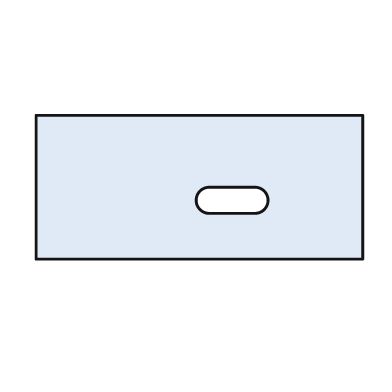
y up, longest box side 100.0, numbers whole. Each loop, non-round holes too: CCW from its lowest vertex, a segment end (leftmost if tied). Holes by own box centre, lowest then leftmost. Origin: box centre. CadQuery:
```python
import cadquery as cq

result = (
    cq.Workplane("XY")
    .moveTo(-50.0, -22.0)
    .lineTo(50.0, -22.0)
    .lineTo(50.0, 22.0)
    .lineTo(-50.0, 22.0)
    .close()
    .moveTo(3.0, -8.0)
    .lineTo(17.0, -8.0)
    .threePointArc((21.0, -4.0), (17.0, 0.0))
    .lineTo(3.0, 0.0)
    .threePointArc((-1.0, -4.0), (3.0, -8.0))
    .close()
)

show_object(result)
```